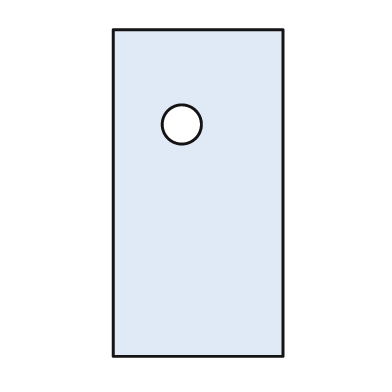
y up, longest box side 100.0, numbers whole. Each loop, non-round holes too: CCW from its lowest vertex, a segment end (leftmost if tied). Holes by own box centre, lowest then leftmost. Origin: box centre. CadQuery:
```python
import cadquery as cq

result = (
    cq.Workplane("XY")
    .moveTo(-26.0, -50.0)
    .lineTo(26.0, -50.0)
    .lineTo(26.0, 50.0)
    .lineTo(-26.0, 50.0)
    .close()
    .moveTo(-5.0, 21.0)
    .circle(6.0)
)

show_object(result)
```